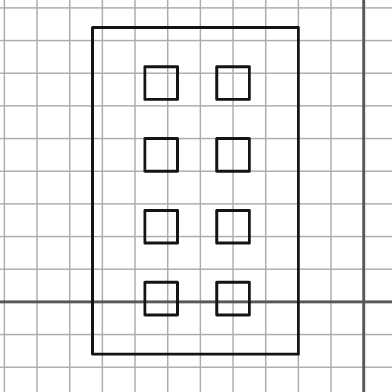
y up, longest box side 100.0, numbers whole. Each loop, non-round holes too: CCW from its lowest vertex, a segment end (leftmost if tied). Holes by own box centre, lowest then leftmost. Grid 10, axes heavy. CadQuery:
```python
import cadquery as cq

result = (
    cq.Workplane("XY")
    .moveTo(-83.0, -16.0)
    .lineTo(-20.0, -16.0)
    .lineTo(-20.0, 84.0)
    .lineTo(-83.0, 84.0)
    .close()
    .moveTo(-67.0, -4.0)
    .lineTo(-57.0, -4.0)
    .lineTo(-57.0, 6.0)
    .lineTo(-67.0, 6.0)
    .close()
    .moveTo(-45.0, -4.0)
    .lineTo(-35.0, -4.0)
    .lineTo(-35.0, 6.0)
    .lineTo(-45.0, 6.0)
    .close()
    .moveTo(-67.0, 18.0)
    .lineTo(-57.0, 18.0)
    .lineTo(-57.0, 28.0)
    .lineTo(-67.0, 28.0)
    .close()
    .moveTo(-45.0, 18.0)
    .lineTo(-35.0, 18.0)
    .lineTo(-35.0, 28.0)
    .lineTo(-45.0, 28.0)
    .close()
    .moveTo(-67.0, 40.0)
    .lineTo(-57.0, 40.0)
    .lineTo(-57.0, 50.0)
    .lineTo(-67.0, 50.0)
    .close()
    .moveTo(-45.0, 40.0)
    .lineTo(-35.0, 40.0)
    .lineTo(-35.0, 50.0)
    .lineTo(-45.0, 50.0)
    .close()
    .moveTo(-67.0, 62.0)
    .lineTo(-57.0, 62.0)
    .lineTo(-57.0, 72.0)
    .lineTo(-67.0, 72.0)
    .close()
    .moveTo(-45.0, 62.0)
    .lineTo(-35.0, 62.0)
    .lineTo(-35.0, 72.0)
    .lineTo(-45.0, 72.0)
    .close()
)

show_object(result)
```